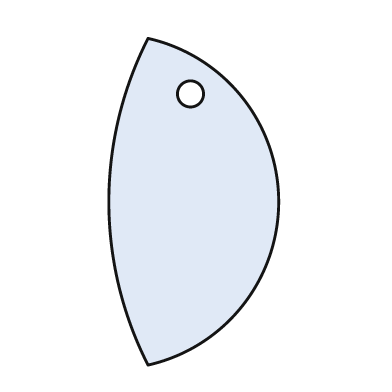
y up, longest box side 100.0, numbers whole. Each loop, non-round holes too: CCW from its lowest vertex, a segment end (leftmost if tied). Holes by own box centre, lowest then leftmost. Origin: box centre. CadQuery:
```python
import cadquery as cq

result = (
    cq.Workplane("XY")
    .moveTo(-14.0, -50.0)
    .threePointArc((26.0, 0.0), (-14.0, 50.0))
    .threePointArc((-26.0, 0.0), (-14.0, -50.0))
    .close()
    .moveTo(-1.0, 33.0)
    .circle(4.0)
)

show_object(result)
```